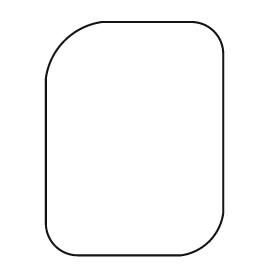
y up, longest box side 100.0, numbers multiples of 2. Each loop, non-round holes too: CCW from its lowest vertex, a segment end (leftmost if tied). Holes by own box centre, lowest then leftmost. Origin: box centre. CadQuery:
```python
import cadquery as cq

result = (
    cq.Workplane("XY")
    .moveTo(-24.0, -50.0)
    .lineTo(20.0, -50.0)
    .threePointArc((32.0, -44.0), (38.0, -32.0))
    .lineTo(38.0, 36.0)
    .threePointArc((34.0, 46.0), (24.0, 50.0))
    .lineTo(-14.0, 50.0)
    .threePointArc((-30.0, 42.0), (-38.0, 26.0))
    .lineTo(-38.0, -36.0)
    .threePointArc((-34.0, -46.0), (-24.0, -50.0))
    .close()
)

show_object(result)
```